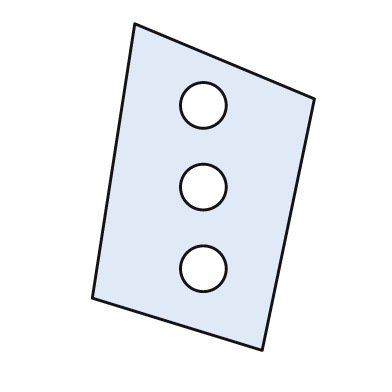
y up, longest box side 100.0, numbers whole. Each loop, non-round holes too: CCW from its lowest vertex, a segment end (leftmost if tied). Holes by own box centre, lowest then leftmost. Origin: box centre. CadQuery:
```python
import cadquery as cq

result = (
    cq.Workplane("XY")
    .moveTo(18.0, -50.0)
    .lineTo(34.0, 27.0)
    .lineTo(-21.0, 50.0)
    .lineTo(-34.0, -34.0)
    .close()
    .moveTo(0.0, -25.0)
    .circle(7.0)
    .moveTo(0.0, 0.0)
    .circle(7.0)
    .moveTo(0.0, 25.0)
    .circle(7.0)
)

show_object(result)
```